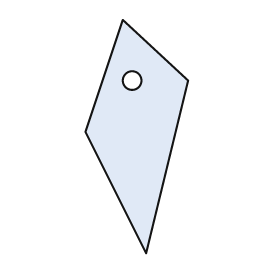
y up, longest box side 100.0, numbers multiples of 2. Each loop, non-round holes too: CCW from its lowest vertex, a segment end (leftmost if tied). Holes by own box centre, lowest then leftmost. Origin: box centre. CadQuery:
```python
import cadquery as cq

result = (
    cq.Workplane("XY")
    .moveTo(4.0, -50.0)
    .lineTo(22.0, 24.0)
    .lineTo(-6.0, 50.0)
    .lineTo(-22.0, 2.0)
    .close()
    .moveTo(-2.0, 24.0)
    .circle(4.0)
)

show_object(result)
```